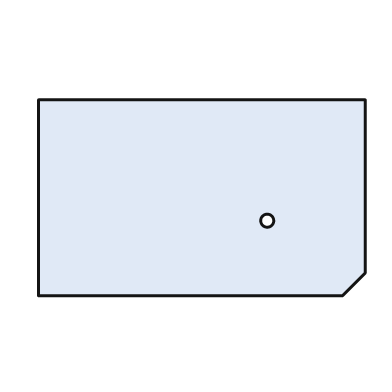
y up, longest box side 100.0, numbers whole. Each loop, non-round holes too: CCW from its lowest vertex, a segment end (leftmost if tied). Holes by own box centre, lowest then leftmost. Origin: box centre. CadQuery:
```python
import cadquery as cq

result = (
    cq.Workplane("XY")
    .moveTo(-50.0, -30.0)
    .lineTo(43.0, -30.0)
    .lineTo(50.0, -23.0)
    .lineTo(50.0, 30.0)
    .lineTo(-50.0, 30.0)
    .close()
    .moveTo(20.0, -7.0)
    .circle(2.0)
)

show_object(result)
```